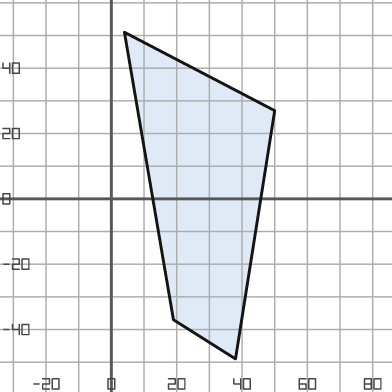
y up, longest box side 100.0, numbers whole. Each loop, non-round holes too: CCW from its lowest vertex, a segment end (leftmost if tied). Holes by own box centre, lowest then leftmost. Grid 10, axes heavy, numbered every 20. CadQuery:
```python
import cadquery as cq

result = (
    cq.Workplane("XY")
    .moveTo(38.0, -49.0)
    .lineTo(50.0, 27.0)
    .lineTo(4.0, 51.0)
    .lineTo(19.0, -37.0)
    .close()
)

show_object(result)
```